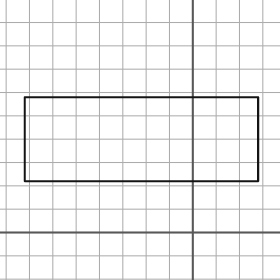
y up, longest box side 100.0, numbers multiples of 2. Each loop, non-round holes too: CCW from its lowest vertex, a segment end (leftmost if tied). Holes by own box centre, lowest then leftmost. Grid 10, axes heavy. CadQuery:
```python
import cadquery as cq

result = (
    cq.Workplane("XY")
    .moveTo(-72.0, 22.0)
    .lineTo(28.0, 22.0)
    .lineTo(28.0, 58.0)
    .lineTo(-72.0, 58.0)
    .close()
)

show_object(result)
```